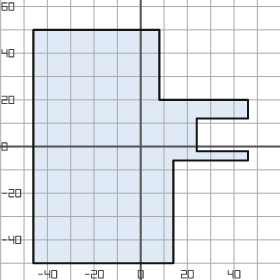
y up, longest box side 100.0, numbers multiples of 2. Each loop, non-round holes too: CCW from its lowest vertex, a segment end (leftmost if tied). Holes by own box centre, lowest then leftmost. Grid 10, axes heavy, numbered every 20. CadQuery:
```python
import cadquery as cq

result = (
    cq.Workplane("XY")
    .moveTo(-46.0, -50.0)
    .lineTo(14.0, -50.0)
    .lineTo(14.0, -6.0)
    .lineTo(46.0, -6.0)
    .lineTo(46.0, -2.0)
    .lineTo(24.0, -2.0)
    .lineTo(24.0, 12.0)
    .lineTo(46.0, 12.0)
    .lineTo(46.0, 20.0)
    .lineTo(8.0, 20.0)
    .lineTo(8.0, 50.0)
    .lineTo(-46.0, 50.0)
    .close()
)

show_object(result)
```